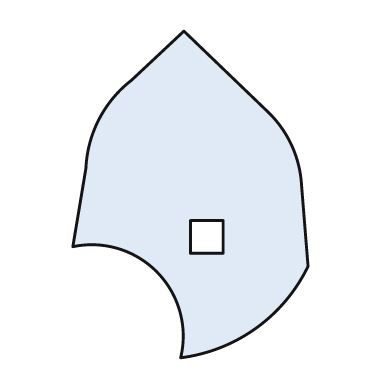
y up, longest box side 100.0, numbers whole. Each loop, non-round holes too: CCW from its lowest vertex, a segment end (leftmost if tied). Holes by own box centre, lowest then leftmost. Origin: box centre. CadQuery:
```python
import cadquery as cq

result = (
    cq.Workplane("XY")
    .moveTo(-3.0, -50.0)
    .threePointArc((20.0, -41.0), (36.0, -22.0))
    .lineTo(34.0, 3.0)
    .threePointArc((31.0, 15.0), (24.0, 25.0))
    .lineTo(-2.0, 50.0)
    .lineTo(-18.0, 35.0)
    .threePointArc((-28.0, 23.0), (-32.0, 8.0))
    .lineTo(-36.0, -16.0)
    .threePointArc((-10.0, -24.0), (-3.0, -50.0))
    .close()
    .moveTo(0.0, -18.0)
    .lineTo(10.0, -18.0)
    .lineTo(10.0, -8.0)
    .lineTo(0.0, -8.0)
    .close()
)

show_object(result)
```